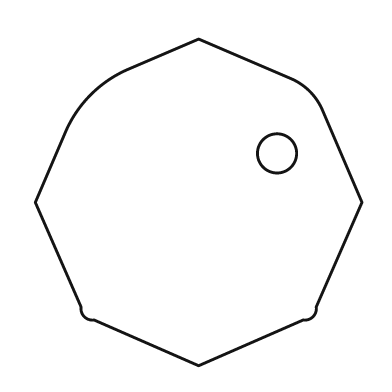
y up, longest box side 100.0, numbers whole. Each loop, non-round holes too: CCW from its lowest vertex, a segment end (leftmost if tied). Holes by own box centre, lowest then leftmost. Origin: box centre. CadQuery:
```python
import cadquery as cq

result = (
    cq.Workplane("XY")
    .moveTo(0.0, -50.0)
    .lineTo(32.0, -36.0)
    .threePointArc((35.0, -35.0), (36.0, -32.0))
    .lineTo(50.0, 0.0)
    .lineTo(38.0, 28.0)
    .threePointArc((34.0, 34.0), (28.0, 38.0))
    .lineTo(0.0, 50.0)
    .lineTo(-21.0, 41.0)
    .threePointArc((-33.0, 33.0), (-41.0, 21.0))
    .lineTo(-50.0, 0.0)
    .lineTo(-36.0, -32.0)
    .threePointArc((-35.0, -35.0), (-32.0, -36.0))
    .close()
    .moveTo(24.0, 15.0)
    .circle(6.0)
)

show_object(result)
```